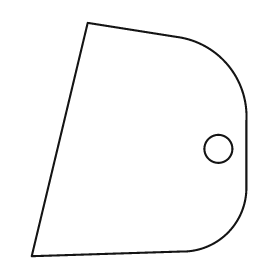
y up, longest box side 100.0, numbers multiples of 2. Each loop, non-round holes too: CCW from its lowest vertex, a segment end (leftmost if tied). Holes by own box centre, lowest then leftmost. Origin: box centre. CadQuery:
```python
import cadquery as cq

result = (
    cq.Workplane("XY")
    .moveTo(-46.0, -50.0)
    .lineTo(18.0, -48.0)
    .threePointArc((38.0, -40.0), (46.0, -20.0))
    .lineTo(46.0, 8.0)
    .threePointArc((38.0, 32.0), (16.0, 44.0))
    .lineTo(-22.0, 50.0)
    .close()
    .moveTo(34.0, -4.0)
    .circle(6.0)
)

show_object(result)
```